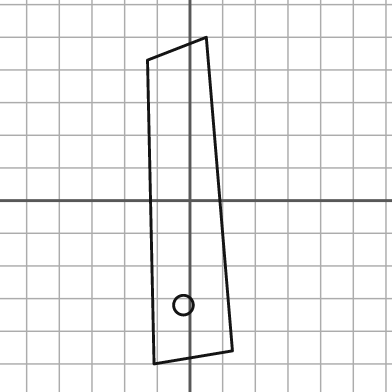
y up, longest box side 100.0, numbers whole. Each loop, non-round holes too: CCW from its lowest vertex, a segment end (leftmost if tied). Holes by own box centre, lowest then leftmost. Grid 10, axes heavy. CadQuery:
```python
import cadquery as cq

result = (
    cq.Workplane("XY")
    .moveTo(-11.0, -50.0)
    .lineTo(13.0, -46.0)
    .lineTo(5.0, 50.0)
    .lineTo(-13.0, 43.0)
    .close()
    .moveTo(-2.0, -32.0)
    .circle(3.0)
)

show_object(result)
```